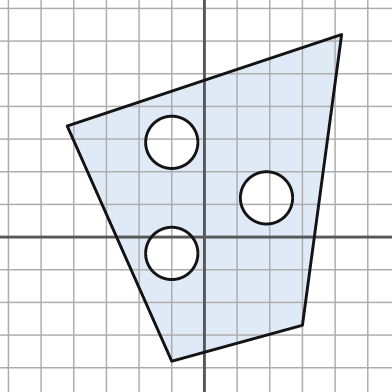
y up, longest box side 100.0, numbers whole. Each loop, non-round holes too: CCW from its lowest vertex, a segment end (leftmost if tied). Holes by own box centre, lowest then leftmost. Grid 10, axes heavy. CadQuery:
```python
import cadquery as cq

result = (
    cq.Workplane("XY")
    .moveTo(-10.0, -38.0)
    .lineTo(30.0, -27.0)
    .lineTo(42.0, 62.0)
    .lineTo(-42.0, 34.0)
    .close()
    .moveTo(-10.0, -5.0)
    .circle(8.0)
    .moveTo(19.0, 12.0)
    .circle(8.0)
    .moveTo(-10.0, 29.0)
    .circle(8.0)
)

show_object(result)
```